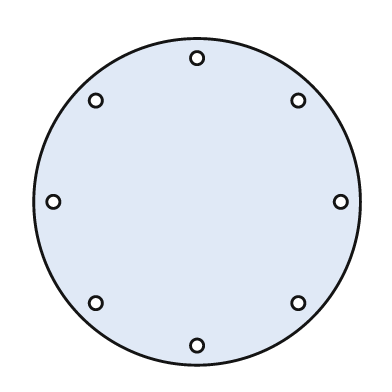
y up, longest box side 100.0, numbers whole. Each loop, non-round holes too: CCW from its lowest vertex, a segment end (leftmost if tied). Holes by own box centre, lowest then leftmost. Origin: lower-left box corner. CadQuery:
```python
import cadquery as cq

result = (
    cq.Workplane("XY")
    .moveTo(50.0, 50.0)
    .circle(50.0)
    .moveTo(50.0, 6.0)
    .circle(2.0)
    .moveTo(19.0, 19.0)
    .circle(2.0)
    .moveTo(81.0, 19.0)
    .circle(2.0)
    .moveTo(6.0, 50.0)
    .circle(2.0)
    .moveTo(94.0, 50.0)
    .circle(2.0)
    .moveTo(19.0, 81.0)
    .circle(2.0)
    .moveTo(81.0, 81.0)
    .circle(2.0)
    .moveTo(50.0, 94.0)
    .circle(2.0)
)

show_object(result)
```